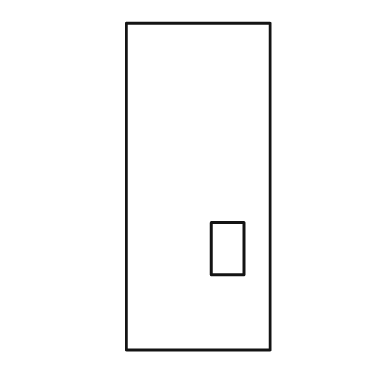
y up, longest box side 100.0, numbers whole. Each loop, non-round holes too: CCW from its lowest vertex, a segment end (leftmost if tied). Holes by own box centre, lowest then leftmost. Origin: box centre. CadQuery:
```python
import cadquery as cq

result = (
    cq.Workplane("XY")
    .moveTo(-22.0, -50.0)
    .lineTo(22.0, -50.0)
    .lineTo(22.0, 50.0)
    .lineTo(-22.0, 50.0)
    .close()
    .moveTo(4.0, -27.0)
    .lineTo(14.0, -27.0)
    .lineTo(14.0, -11.0)
    .lineTo(4.0, -11.0)
    .close()
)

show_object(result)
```